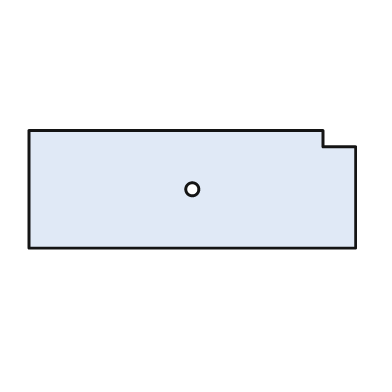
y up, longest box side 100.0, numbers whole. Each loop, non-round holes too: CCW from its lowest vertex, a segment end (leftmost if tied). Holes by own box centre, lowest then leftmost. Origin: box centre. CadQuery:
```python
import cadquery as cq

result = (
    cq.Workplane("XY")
    .moveTo(-50.0, -18.0)
    .lineTo(50.0, -18.0)
    .lineTo(50.0, 13.0)
    .lineTo(40.0, 13.0)
    .lineTo(40.0, 18.0)
    .lineTo(-50.0, 18.0)
    .close()
    .moveTo(0.0, 0.0)
    .circle(2.0)
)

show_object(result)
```